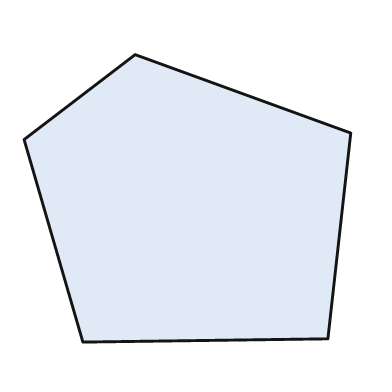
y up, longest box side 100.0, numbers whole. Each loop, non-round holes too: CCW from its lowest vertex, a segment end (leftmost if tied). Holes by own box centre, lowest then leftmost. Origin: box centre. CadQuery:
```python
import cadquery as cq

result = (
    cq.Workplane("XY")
    .moveTo(-32.0, -44.0)
    .lineTo(43.0, -43.0)
    .lineTo(50.0, 20.0)
    .lineTo(-16.0, 44.0)
    .lineTo(-50.0, 18.0)
    .close()
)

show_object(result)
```